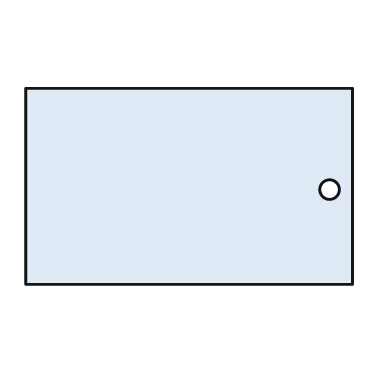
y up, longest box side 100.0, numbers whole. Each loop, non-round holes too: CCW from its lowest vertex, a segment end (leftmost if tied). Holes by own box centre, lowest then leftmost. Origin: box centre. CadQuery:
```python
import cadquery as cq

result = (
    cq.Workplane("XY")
    .moveTo(-50.0, -30.0)
    .lineTo(50.0, -30.0)
    .lineTo(50.0, 30.0)
    .lineTo(-50.0, 30.0)
    .close()
    .moveTo(43.0, -1.0)
    .circle(3.0)
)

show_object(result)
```